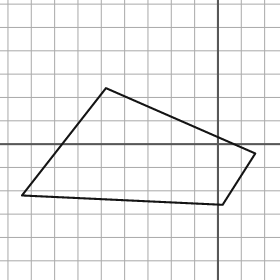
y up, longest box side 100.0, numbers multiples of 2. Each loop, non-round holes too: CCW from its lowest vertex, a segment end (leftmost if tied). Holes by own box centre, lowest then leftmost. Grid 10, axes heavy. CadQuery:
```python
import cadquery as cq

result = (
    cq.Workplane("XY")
    .moveTo(2.0, -26.0)
    .lineTo(16.0, -4.0)
    .lineTo(-48.0, 24.0)
    .lineTo(-84.0, -22.0)
    .close()
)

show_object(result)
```